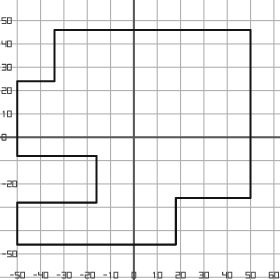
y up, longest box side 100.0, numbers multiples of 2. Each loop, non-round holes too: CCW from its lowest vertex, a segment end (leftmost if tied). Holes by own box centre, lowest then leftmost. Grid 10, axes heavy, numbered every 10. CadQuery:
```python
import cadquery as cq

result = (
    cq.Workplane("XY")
    .moveTo(-50.0, -46.0)
    .lineTo(18.0, -46.0)
    .lineTo(18.0, -26.0)
    .lineTo(50.0, -26.0)
    .lineTo(50.0, 46.0)
    .lineTo(-34.0, 46.0)
    .lineTo(-34.0, 24.0)
    .lineTo(-50.0, 24.0)
    .lineTo(-50.0, -8.0)
    .lineTo(-16.0, -8.0)
    .lineTo(-16.0, -28.0)
    .lineTo(-50.0, -28.0)
    .close()
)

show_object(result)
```